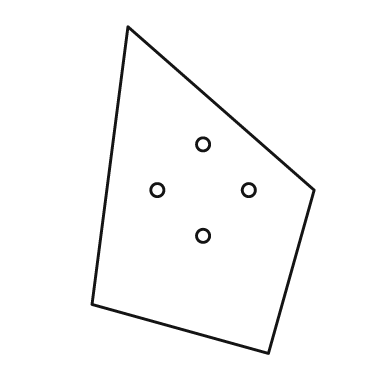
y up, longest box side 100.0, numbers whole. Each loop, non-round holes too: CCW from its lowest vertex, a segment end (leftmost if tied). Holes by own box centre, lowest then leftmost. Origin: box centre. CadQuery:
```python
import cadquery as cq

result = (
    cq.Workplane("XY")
    .moveTo(20.0, -50.0)
    .lineTo(34.0, 0.0)
    .lineTo(-23.0, 50.0)
    .lineTo(-34.0, -35.0)
    .close()
    .moveTo(0.0, -14.0)
    .circle(2.0)
    .moveTo(-14.0, 0.0)
    .circle(2.0)
    .moveTo(14.0, 0.0)
    .circle(2.0)
    .moveTo(0.0, 14.0)
    .circle(2.0)
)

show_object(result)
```